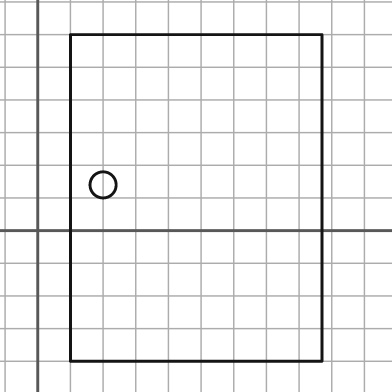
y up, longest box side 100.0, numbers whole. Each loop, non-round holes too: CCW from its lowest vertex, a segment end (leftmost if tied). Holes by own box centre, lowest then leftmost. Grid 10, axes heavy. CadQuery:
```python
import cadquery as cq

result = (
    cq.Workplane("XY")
    .moveTo(10.0, -40.0)
    .lineTo(87.0, -40.0)
    .lineTo(87.0, 60.0)
    .lineTo(10.0, 60.0)
    .close()
    .moveTo(20.0, 14.0)
    .circle(4.0)
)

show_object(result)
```